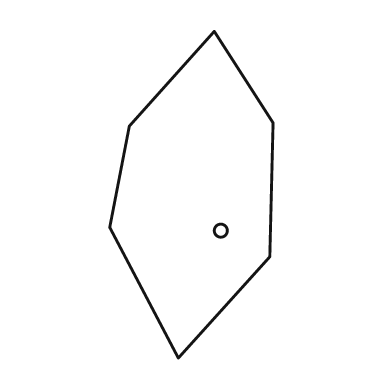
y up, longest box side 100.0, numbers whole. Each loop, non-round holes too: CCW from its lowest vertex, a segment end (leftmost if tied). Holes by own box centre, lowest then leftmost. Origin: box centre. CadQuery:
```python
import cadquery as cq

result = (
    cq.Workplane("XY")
    .moveTo(-4.0, -50.0)
    .lineTo(24.0, -19.0)
    .lineTo(25.0, 22.0)
    .lineTo(7.0, 50.0)
    .lineTo(-19.0, 21.0)
    .lineTo(-25.0, -10.0)
    .close()
    .moveTo(9.0, -11.0)
    .circle(2.0)
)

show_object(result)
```